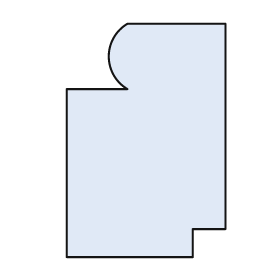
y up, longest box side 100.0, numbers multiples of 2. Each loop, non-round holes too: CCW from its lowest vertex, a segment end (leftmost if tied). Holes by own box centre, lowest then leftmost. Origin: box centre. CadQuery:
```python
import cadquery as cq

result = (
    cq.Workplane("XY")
    .moveTo(-34.0, -50.0)
    .lineTo(20.0, -50.0)
    .lineTo(20.0, -38.0)
    .lineTo(34.0, -38.0)
    .lineTo(34.0, 50.0)
    .lineTo(-8.0, 50.0)
    .threePointArc((-16.0, 36.0), (-8.0, 22.0))
    .lineTo(-34.0, 22.0)
    .close()
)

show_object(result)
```